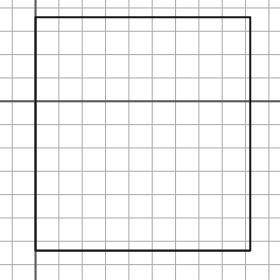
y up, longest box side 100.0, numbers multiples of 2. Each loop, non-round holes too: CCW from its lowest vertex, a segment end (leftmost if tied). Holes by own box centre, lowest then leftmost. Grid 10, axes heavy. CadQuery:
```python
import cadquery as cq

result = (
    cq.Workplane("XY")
    .moveTo(0.0, -64.0)
    .lineTo(92.0, -64.0)
    .lineTo(92.0, 36.0)
    .lineTo(0.0, 36.0)
    .close()
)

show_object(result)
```